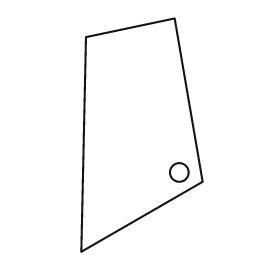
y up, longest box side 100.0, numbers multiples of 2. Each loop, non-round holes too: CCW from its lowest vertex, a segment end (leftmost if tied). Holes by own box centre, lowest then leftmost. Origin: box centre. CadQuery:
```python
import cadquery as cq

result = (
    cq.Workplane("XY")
    .moveTo(-26.0, -50.0)
    .lineTo(26.0, -20.0)
    .lineTo(14.0, 50.0)
    .lineTo(-24.0, 42.0)
    .close()
    .moveTo(16.0, -16.0)
    .circle(4.0)
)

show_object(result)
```